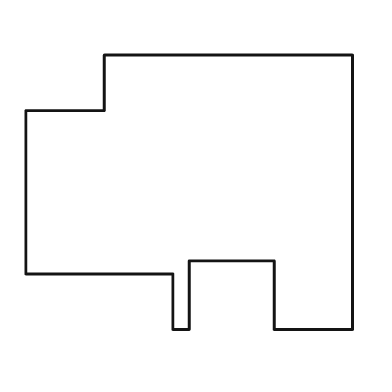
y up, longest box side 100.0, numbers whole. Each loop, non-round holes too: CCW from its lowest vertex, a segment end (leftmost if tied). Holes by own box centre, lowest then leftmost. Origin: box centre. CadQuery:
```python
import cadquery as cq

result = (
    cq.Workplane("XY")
    .moveTo(-5.0, -42.0)
    .lineTo(0.0, -42.0)
    .lineTo(0.0, -21.0)
    .lineTo(26.0, -21.0)
    .lineTo(26.0, -42.0)
    .lineTo(50.0, -42.0)
    .lineTo(50.0, 42.0)
    .lineTo(-26.0, 42.0)
    .lineTo(-26.0, 25.0)
    .lineTo(-50.0, 25.0)
    .lineTo(-50.0, -25.0)
    .lineTo(-5.0, -25.0)
    .close()
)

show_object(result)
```